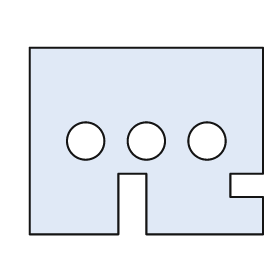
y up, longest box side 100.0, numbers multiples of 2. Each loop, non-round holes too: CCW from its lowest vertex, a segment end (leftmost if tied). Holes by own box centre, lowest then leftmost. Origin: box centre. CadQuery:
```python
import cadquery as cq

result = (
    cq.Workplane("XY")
    .moveTo(-50.0, -40.0)
    .lineTo(-12.0, -40.0)
    .lineTo(-12.0, -14.0)
    .lineTo(0.0, -14.0)
    .lineTo(0.0, -40.0)
    .lineTo(50.0, -40.0)
    .lineTo(50.0, -24.0)
    .lineTo(36.0, -24.0)
    .lineTo(36.0, -14.0)
    .lineTo(50.0, -14.0)
    .lineTo(50.0, 40.0)
    .lineTo(-50.0, 40.0)
    .close()
    .moveTo(-26.0, 0.0)
    .circle(8.0)
    .moveTo(0.0, 0.0)
    .circle(8.0)
    .moveTo(26.0, 0.0)
    .circle(8.0)
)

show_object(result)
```